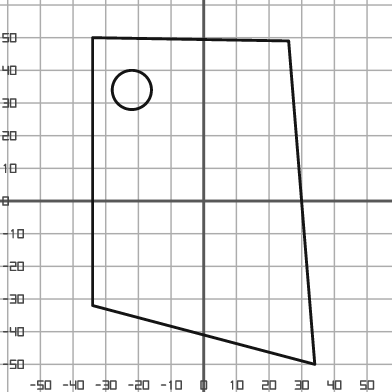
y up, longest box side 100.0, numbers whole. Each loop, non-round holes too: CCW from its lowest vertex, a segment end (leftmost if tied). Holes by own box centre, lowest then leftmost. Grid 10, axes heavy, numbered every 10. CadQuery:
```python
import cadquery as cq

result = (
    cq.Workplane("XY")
    .moveTo(34.0, -50.0)
    .lineTo(26.0, 49.0)
    .lineTo(-34.0, 50.0)
    .lineTo(-34.0, -32.0)
    .close()
    .moveTo(-22.0, 34.0)
    .circle(6.0)
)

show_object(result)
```